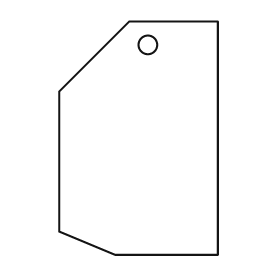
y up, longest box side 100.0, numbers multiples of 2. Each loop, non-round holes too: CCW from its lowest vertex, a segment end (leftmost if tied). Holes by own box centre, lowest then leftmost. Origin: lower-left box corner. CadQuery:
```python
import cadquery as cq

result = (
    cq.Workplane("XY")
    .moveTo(24.0, 0.0)
    .lineTo(68.0, 0.0)
    .lineTo(68.0, 100.0)
    .lineTo(30.0, 100.0)
    .lineTo(0.0, 70.0)
    .lineTo(0.0, 10.0)
    .close()
    .moveTo(38.0, 90.0)
    .circle(4.0)
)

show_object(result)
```